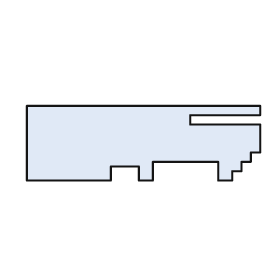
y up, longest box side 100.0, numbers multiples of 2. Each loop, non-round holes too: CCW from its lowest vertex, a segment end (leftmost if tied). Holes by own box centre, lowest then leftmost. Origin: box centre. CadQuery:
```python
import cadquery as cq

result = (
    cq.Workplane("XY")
    .moveTo(-50.0, -16.0)
    .lineTo(-14.0, -16.0)
    .lineTo(-14.0, -10.0)
    .lineTo(-2.0, -10.0)
    .lineTo(-2.0, -16.0)
    .lineTo(4.0, -16.0)
    .lineTo(4.0, -8.0)
    .lineTo(32.0, -8.0)
    .lineTo(32.0, -16.0)
    .lineTo(38.0, -16.0)
    .lineTo(38.0, -12.0)
    .lineTo(42.0, -12.0)
    .lineTo(42.0, -8.0)
    .lineTo(46.0, -8.0)
    .lineTo(46.0, -4.0)
    .lineTo(50.0, -4.0)
    .lineTo(50.0, 8.0)
    .lineTo(20.0, 8.0)
    .lineTo(20.0, 12.0)
    .lineTo(50.0, 12.0)
    .lineTo(50.0, 16.0)
    .lineTo(-50.0, 16.0)
    .close()
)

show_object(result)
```